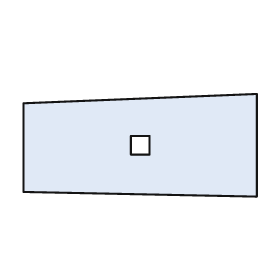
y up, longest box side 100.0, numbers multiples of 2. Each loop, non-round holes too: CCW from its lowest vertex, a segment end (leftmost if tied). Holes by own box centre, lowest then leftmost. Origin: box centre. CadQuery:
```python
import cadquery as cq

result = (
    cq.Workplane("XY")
    .moveTo(50.0, -22.0)
    .lineTo(50.0, 22.0)
    .lineTo(-50.0, 18.0)
    .lineTo(-50.0, -20.0)
    .close()
    .moveTo(-4.0, -4.0)
    .lineTo(4.0, -4.0)
    .lineTo(4.0, 4.0)
    .lineTo(-4.0, 4.0)
    .close()
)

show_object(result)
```